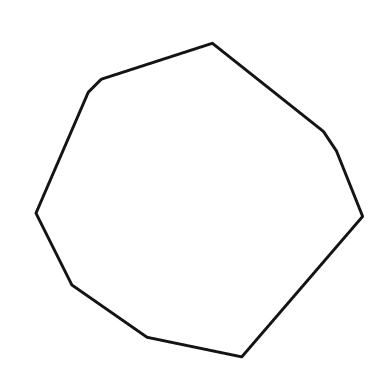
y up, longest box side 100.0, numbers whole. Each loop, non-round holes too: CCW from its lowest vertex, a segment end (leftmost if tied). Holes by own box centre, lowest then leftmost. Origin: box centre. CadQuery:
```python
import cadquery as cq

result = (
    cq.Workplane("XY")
    .moveTo(13.0, -48.0)
    .lineTo(50.0, -5.0)
    .lineTo(42.0, 15.0)
    .lineTo(38.0, 21.0)
    .lineTo(4.0, 48.0)
    .lineTo(-30.0, 37.0)
    .lineTo(-34.0, 33.0)
    .lineTo(-50.0, -4.0)
    .lineTo(-39.0, -26.0)
    .lineTo(-16.0, -42.0)
    .close()
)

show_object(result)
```